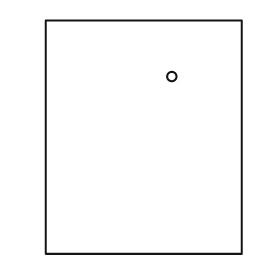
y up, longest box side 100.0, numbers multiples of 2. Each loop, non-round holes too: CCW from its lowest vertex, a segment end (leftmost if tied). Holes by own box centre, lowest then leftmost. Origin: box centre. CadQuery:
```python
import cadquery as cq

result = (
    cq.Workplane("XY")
    .moveTo(-42.0, -50.0)
    .lineTo(42.0, -50.0)
    .lineTo(42.0, 50.0)
    .lineTo(-42.0, 50.0)
    .close()
    .moveTo(12.0, 26.0)
    .circle(2.0)
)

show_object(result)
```